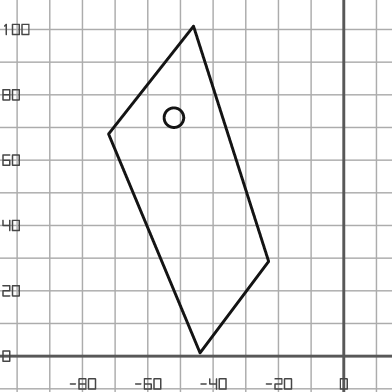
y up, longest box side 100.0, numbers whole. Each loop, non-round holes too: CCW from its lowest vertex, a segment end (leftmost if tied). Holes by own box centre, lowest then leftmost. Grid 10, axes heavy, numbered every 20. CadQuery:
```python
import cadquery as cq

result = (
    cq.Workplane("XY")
    .moveTo(-44.0, 1.0)
    .lineTo(-23.0, 29.0)
    .lineTo(-46.0, 101.0)
    .lineTo(-72.0, 68.0)
    .close()
    .moveTo(-52.0, 73.0)
    .circle(3.0)
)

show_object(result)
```